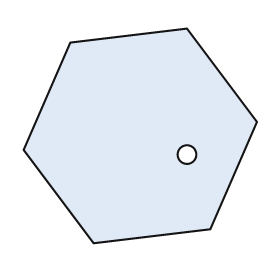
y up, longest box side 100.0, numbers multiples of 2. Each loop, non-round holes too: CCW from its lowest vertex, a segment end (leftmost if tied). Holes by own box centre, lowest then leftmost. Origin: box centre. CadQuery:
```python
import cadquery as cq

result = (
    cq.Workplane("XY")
    .moveTo(-20.0, -46.0)
    .lineTo(30.0, -40.0)
    .lineTo(50.0, 6.0)
    .lineTo(20.0, 46.0)
    .lineTo(-30.0, 40.0)
    .lineTo(-50.0, -6.0)
    .close()
    .moveTo(20.0, -8.0)
    .circle(4.0)
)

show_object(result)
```